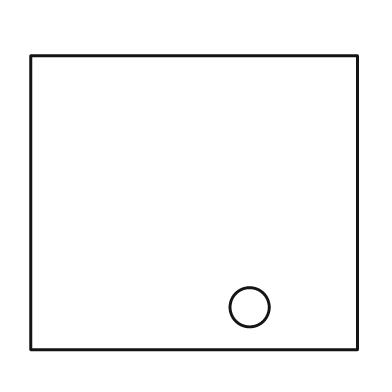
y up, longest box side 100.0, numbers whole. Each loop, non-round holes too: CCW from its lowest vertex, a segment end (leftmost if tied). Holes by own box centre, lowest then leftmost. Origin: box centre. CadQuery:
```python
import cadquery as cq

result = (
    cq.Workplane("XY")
    .moveTo(-50.0, -45.0)
    .lineTo(50.0, -45.0)
    .lineTo(50.0, 45.0)
    .lineTo(-50.0, 45.0)
    .close()
    .moveTo(17.0, -32.0)
    .circle(6.0)
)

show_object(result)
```